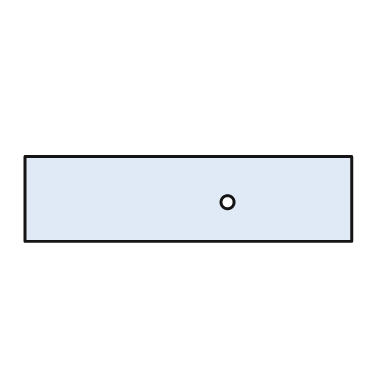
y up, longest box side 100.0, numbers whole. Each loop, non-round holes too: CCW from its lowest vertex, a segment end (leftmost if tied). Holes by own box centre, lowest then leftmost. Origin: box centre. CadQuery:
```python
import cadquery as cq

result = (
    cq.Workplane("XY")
    .moveTo(-50.0, -13.0)
    .lineTo(50.0, -13.0)
    .lineTo(50.0, 13.0)
    .lineTo(-50.0, 13.0)
    .close()
    .moveTo(12.0, -1.0)
    .circle(2.0)
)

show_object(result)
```